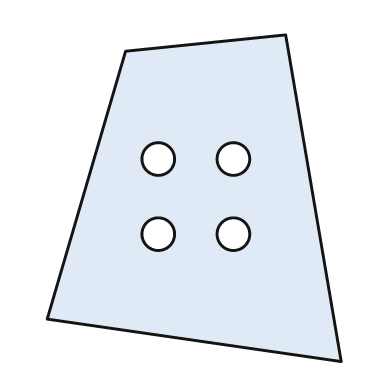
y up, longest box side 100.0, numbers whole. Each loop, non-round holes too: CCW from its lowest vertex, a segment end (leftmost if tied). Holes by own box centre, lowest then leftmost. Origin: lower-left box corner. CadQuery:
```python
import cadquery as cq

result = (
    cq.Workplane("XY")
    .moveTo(90.0, 0.0)
    .lineTo(73.0, 100.0)
    .lineTo(24.0, 95.0)
    .lineTo(0.0, 13.0)
    .close()
    .moveTo(34.0, 39.0)
    .circle(5.0)
    .moveTo(57.0, 39.0)
    .circle(5.0)
    .moveTo(34.0, 62.0)
    .circle(5.0)
    .moveTo(57.0, 62.0)
    .circle(5.0)
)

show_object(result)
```